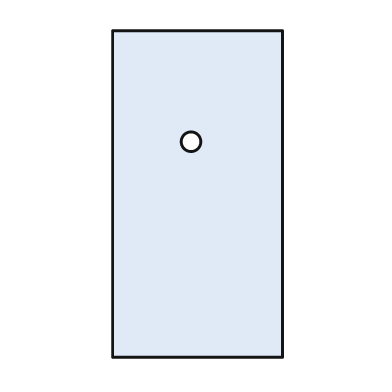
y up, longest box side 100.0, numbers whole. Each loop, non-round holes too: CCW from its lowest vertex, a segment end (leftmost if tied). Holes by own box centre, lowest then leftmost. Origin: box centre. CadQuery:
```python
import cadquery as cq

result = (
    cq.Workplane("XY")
    .moveTo(-26.0, -50.0)
    .lineTo(26.0, -50.0)
    .lineTo(26.0, 50.0)
    .lineTo(-26.0, 50.0)
    .close()
    .moveTo(-2.0, 16.0)
    .circle(3.0)
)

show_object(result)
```